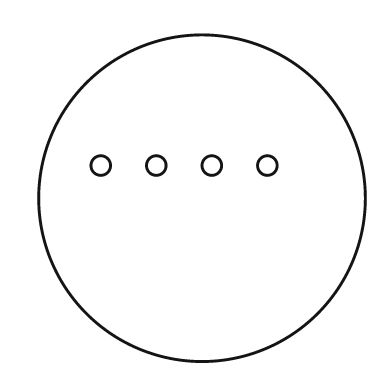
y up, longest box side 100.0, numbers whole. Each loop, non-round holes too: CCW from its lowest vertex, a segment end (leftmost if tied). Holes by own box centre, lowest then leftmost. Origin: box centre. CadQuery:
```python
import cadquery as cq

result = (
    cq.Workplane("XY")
    .moveTo(0.0, 0.0)
    .circle(50.0)
    .moveTo(-31.0, 10.0)
    .circle(3.0)
    .moveTo(-14.0, 10.0)
    .circle(3.0)
    .moveTo(3.0, 10.0)
    .circle(3.0)
    .moveTo(20.0, 10.0)
    .circle(3.0)
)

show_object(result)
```